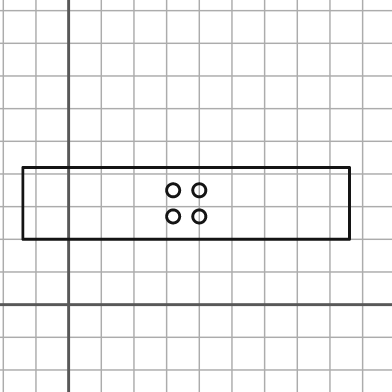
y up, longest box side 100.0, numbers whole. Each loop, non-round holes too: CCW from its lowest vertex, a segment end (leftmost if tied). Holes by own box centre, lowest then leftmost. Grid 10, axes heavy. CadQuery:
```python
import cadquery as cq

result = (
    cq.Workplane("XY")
    .moveTo(-14.0, 20.0)
    .lineTo(86.0, 20.0)
    .lineTo(86.0, 42.0)
    .lineTo(-14.0, 42.0)
    .close()
    .moveTo(32.0, 27.0)
    .circle(2.0)
    .moveTo(40.0, 27.0)
    .circle(2.0)
    .moveTo(32.0, 35.0)
    .circle(2.0)
    .moveTo(40.0, 35.0)
    .circle(2.0)
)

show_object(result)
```